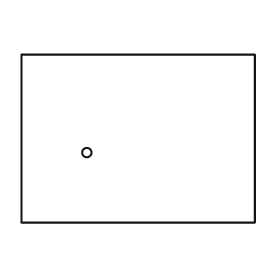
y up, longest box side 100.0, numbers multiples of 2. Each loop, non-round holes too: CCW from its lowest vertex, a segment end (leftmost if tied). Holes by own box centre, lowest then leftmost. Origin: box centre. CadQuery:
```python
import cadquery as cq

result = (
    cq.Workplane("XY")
    .moveTo(-50.0, -36.0)
    .lineTo(50.0, -36.0)
    .lineTo(50.0, 36.0)
    .lineTo(-50.0, 36.0)
    .close()
    .moveTo(-22.0, -6.0)
    .circle(2.0)
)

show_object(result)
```